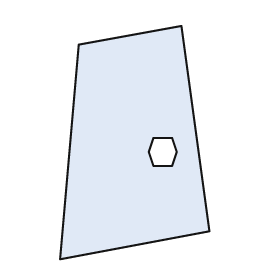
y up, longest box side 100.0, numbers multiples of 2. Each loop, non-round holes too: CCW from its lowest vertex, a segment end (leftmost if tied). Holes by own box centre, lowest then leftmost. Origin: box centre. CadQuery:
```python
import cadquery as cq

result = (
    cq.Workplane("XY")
    .moveTo(-32.0, -50.0)
    .lineTo(32.0, -38.0)
    .lineTo(20.0, 50.0)
    .lineTo(-24.0, 42.0)
    .close()
    .moveTo(8.0, -10.0)
    .lineTo(16.0, -10.0)
    .lineTo(18.0, -4.0)
    .lineTo(16.0, 2.0)
    .lineTo(8.0, 2.0)
    .lineTo(6.0, -4.0)
    .close()
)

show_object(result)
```